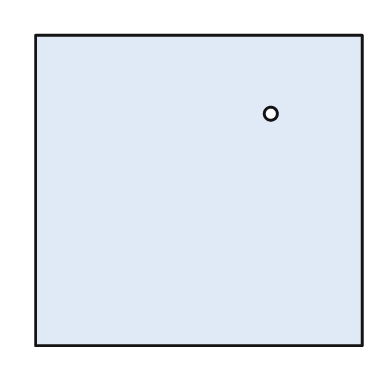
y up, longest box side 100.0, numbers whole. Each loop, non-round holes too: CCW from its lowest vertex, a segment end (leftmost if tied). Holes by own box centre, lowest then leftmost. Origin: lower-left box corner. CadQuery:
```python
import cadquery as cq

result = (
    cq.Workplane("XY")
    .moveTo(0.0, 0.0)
    .lineTo(100.0, 0.0)
    .lineTo(100.0, 95.0)
    .lineTo(0.0, 95.0)
    .close()
    .moveTo(72.0, 71.0)
    .circle(2.0)
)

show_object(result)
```